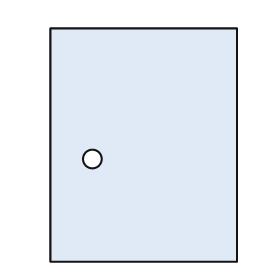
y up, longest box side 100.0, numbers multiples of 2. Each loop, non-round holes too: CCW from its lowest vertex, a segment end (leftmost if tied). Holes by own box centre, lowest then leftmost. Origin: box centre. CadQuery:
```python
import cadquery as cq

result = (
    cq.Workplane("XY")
    .moveTo(-40.0, -50.0)
    .lineTo(40.0, -50.0)
    .lineTo(40.0, 50.0)
    .lineTo(-40.0, 50.0)
    .close()
    .moveTo(-22.0, -6.0)
    .circle(4.0)
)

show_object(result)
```